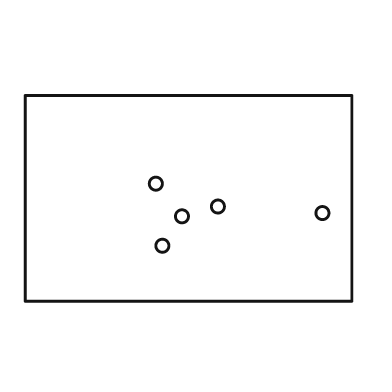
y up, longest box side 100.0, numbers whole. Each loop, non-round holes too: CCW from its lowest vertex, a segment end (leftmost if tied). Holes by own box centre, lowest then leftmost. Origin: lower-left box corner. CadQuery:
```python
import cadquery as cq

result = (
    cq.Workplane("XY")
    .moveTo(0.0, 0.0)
    .lineTo(100.0, 0.0)
    .lineTo(100.0, 63.0)
    .lineTo(0.0, 63.0)
    .close()
    .moveTo(42.0, 17.0)
    .circle(2.0)
    .moveTo(48.0, 26.0)
    .circle(2.0)
    .moveTo(91.0, 27.0)
    .circle(2.0)
    .moveTo(59.0, 29.0)
    .circle(2.0)
    .moveTo(40.0, 36.0)
    .circle(2.0)
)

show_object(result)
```